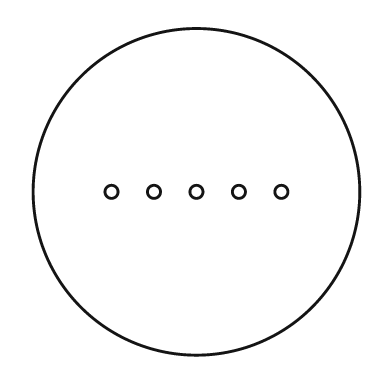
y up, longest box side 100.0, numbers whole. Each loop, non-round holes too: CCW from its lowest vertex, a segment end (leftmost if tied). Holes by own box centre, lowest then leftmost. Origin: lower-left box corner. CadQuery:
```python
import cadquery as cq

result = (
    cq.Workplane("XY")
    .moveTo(50.0, 50.0)
    .circle(50.0)
    .moveTo(24.0, 50.0)
    .circle(2.0)
    .moveTo(37.0, 50.0)
    .circle(2.0)
    .moveTo(50.0, 50.0)
    .circle(2.0)
    .moveTo(63.0, 50.0)
    .circle(2.0)
    .moveTo(76.0, 50.0)
    .circle(2.0)
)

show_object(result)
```